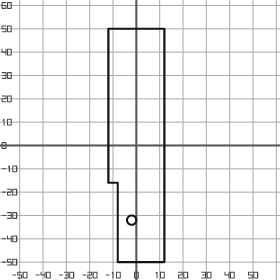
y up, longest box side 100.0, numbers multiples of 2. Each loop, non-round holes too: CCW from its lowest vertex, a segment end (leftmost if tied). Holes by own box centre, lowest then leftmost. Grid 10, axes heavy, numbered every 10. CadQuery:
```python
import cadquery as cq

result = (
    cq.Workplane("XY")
    .moveTo(-8.0, -50.0)
    .lineTo(12.0, -50.0)
    .lineTo(12.0, 50.0)
    .lineTo(-12.0, 50.0)
    .lineTo(-12.0, -16.0)
    .lineTo(-8.0, -16.0)
    .close()
    .moveTo(-2.0, -32.0)
    .circle(2.0)
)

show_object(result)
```